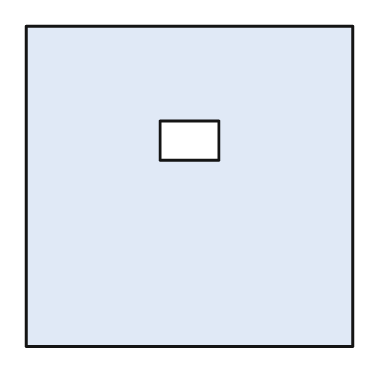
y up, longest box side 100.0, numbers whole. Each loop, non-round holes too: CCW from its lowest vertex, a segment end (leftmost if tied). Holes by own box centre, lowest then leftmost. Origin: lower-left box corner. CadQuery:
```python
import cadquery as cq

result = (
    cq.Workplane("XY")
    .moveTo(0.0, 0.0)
    .lineTo(100.0, 0.0)
    .lineTo(100.0, 98.0)
    .lineTo(0.0, 98.0)
    .close()
    .moveTo(41.0, 57.0)
    .lineTo(59.0, 57.0)
    .lineTo(59.0, 69.0)
    .lineTo(41.0, 69.0)
    .close()
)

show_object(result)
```